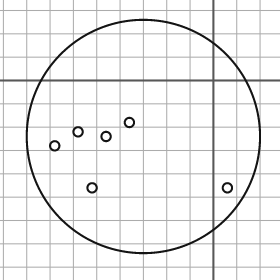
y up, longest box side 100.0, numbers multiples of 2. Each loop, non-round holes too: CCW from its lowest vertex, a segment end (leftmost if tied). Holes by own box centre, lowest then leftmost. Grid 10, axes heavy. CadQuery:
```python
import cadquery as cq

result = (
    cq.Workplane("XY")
    .moveTo(-30.0, -24.0)
    .circle(50.0)
    .moveTo(-52.0, -46.0)
    .circle(2.0)
    .moveTo(6.0, -46.0)
    .circle(2.0)
    .moveTo(-68.0, -28.0)
    .circle(2.0)
    .moveTo(-46.0, -24.0)
    .circle(2.0)
    .moveTo(-58.0, -22.0)
    .circle(2.0)
    .moveTo(-36.0, -18.0)
    .circle(2.0)
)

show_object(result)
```